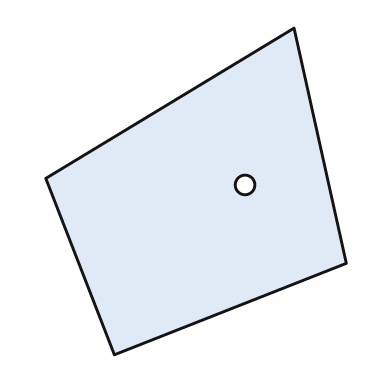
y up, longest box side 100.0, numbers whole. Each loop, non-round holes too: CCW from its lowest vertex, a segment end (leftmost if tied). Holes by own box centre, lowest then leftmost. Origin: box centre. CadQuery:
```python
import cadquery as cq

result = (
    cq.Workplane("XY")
    .moveTo(-25.0, -50.0)
    .lineTo(46.0, -22.0)
    .lineTo(30.0, 50.0)
    .lineTo(-46.0, 4.0)
    .close()
    .moveTo(15.0, 2.0)
    .circle(3.0)
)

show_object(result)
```